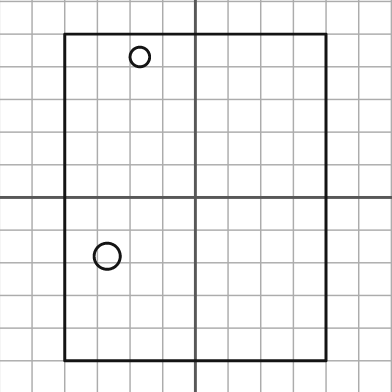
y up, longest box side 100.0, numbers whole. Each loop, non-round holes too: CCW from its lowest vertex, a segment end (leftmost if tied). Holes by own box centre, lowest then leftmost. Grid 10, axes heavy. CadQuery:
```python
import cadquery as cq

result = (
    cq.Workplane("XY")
    .moveTo(-40.0, -50.0)
    .lineTo(40.0, -50.0)
    .lineTo(40.0, 50.0)
    .lineTo(-40.0, 50.0)
    .close()
    .moveTo(-27.0, -18.0)
    .circle(4.0)
    .moveTo(-17.0, 43.0)
    .circle(3.0)
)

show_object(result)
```